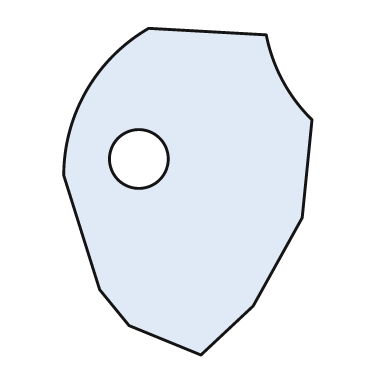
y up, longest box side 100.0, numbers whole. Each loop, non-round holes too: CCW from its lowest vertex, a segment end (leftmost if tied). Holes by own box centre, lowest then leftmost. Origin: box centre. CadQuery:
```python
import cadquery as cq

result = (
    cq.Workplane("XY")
    .moveTo(4.0, -50.0)
    .lineTo(20.0, -35.0)
    .lineTo(35.0, -8.0)
    .lineTo(38.0, 22.0)
    .threePointArc((29.0, 34.0), (24.0, 48.0))
    .lineTo(-12.0, 50.0)
    .threePointArc((-31.0, 31.0), (-38.0, 5.0))
    .lineTo(-27.0, -30.0)
    .lineTo(-18.0, -41.0)
    .close()
    .moveTo(-15.0, 10.0)
    .circle(9.0)
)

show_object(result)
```